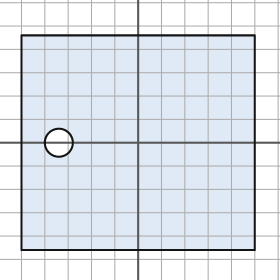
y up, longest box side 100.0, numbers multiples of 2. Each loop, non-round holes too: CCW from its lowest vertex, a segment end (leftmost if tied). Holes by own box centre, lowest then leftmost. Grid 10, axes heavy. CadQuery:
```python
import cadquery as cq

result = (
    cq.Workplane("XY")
    .moveTo(-50.0, -46.0)
    .lineTo(50.0, -46.0)
    .lineTo(50.0, 46.0)
    .lineTo(-50.0, 46.0)
    .close()
    .moveTo(-34.0, 0.0)
    .circle(6.0)
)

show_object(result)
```